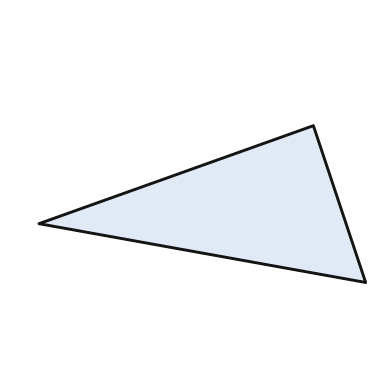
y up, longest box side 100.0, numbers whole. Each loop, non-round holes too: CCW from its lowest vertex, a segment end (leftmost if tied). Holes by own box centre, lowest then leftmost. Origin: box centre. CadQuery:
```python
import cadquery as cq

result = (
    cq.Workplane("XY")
    .moveTo(50.0, -24.0)
    .lineTo(34.0, 24.0)
    .lineTo(-50.0, -6.0)
    .close()
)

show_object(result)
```